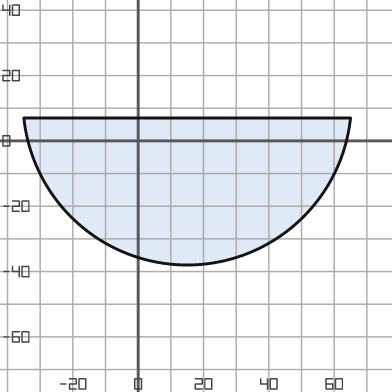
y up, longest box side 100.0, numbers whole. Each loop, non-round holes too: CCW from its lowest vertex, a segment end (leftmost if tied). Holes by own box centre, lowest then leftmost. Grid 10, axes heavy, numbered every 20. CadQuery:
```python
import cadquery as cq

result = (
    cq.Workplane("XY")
    .moveTo(-35.0, 7.0)
    .threePointArc((15.0, -38.0), (65.0, 7.0))
    .close()
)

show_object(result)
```